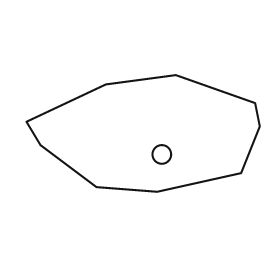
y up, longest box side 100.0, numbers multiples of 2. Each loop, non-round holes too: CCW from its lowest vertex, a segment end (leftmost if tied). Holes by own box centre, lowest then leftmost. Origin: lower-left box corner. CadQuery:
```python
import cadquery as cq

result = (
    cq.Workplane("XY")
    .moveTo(56.0, 0.0)
    .lineTo(92.0, 8.0)
    .lineTo(100.0, 28.0)
    .lineTo(98.0, 38.0)
    .lineTo(64.0, 50.0)
    .lineTo(34.0, 46.0)
    .lineTo(0.0, 30.0)
    .lineTo(6.0, 20.0)
    .lineTo(30.0, 2.0)
    .close()
    .moveTo(58.0, 16.0)
    .circle(4.0)
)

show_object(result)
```